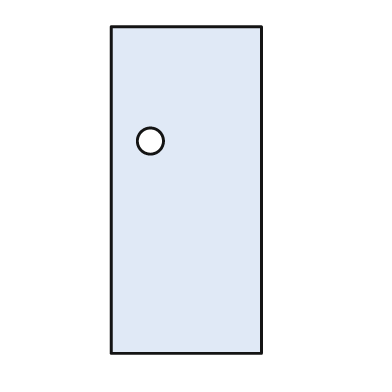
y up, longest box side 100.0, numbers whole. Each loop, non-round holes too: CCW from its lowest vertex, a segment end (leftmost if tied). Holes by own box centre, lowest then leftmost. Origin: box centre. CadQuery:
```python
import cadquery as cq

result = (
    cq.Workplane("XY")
    .moveTo(-23.0, -50.0)
    .lineTo(23.0, -50.0)
    .lineTo(23.0, 50.0)
    .lineTo(-23.0, 50.0)
    .close()
    .moveTo(-11.0, 15.0)
    .circle(4.0)
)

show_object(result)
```